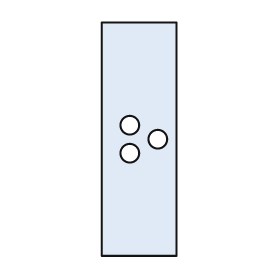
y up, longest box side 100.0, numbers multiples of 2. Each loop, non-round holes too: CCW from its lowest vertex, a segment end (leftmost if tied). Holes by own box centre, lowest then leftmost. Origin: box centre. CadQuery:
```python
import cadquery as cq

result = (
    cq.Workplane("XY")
    .moveTo(-16.0, -50.0)
    .lineTo(16.0, -50.0)
    .lineTo(16.0, 50.0)
    .lineTo(-16.0, 50.0)
    .close()
    .moveTo(-4.0, -6.0)
    .circle(4.0)
    .moveTo(8.0, 0.0)
    .circle(4.0)
    .moveTo(-4.0, 6.0)
    .circle(4.0)
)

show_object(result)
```